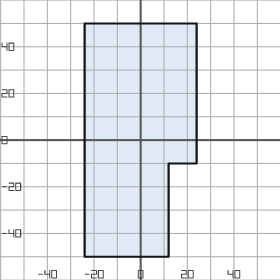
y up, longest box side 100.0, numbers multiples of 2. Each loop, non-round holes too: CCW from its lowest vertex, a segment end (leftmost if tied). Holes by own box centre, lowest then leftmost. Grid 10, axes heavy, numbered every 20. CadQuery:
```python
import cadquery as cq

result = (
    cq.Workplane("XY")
    .moveTo(-24.0, -50.0)
    .lineTo(12.0, -50.0)
    .lineTo(12.0, -10.0)
    .lineTo(24.0, -10.0)
    .lineTo(24.0, 50.0)
    .lineTo(-24.0, 50.0)
    .close()
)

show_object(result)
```